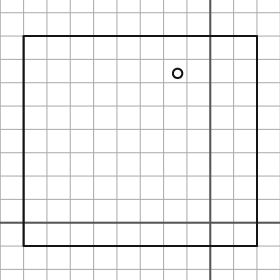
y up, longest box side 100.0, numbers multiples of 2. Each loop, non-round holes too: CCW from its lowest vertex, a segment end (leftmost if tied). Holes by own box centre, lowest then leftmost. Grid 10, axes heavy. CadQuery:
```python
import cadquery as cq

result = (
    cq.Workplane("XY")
    .moveTo(-80.0, -10.0)
    .lineTo(20.0, -10.0)
    .lineTo(20.0, 80.0)
    .lineTo(-80.0, 80.0)
    .close()
    .moveTo(-14.0, 64.0)
    .circle(2.0)
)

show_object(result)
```